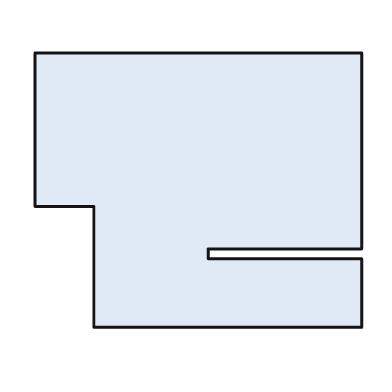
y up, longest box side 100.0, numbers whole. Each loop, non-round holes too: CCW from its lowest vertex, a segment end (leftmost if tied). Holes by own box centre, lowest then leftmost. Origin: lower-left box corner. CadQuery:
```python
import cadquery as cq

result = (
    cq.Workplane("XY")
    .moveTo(18.0, 0.0)
    .lineTo(100.0, 0.0)
    .lineTo(100.0, 21.0)
    .lineTo(53.0, 21.0)
    .lineTo(53.0, 24.0)
    .lineTo(100.0, 24.0)
    .lineTo(100.0, 84.0)
    .lineTo(0.0, 84.0)
    .lineTo(0.0, 37.0)
    .lineTo(18.0, 37.0)
    .close()
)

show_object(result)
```